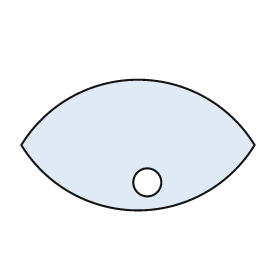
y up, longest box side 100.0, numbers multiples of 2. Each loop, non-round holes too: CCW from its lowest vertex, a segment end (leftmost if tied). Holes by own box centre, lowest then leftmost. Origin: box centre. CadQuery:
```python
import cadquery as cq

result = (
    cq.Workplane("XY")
    .moveTo(-50.0, 0.0)
    .threePointArc((0.0, -28.0), (50.0, 0.0))
    .threePointArc((0.0, 28.0), (-50.0, 0.0))
    .close()
    .moveTo(4.0, -16.0)
    .circle(6.0)
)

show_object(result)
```